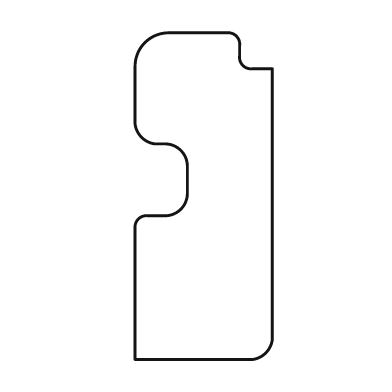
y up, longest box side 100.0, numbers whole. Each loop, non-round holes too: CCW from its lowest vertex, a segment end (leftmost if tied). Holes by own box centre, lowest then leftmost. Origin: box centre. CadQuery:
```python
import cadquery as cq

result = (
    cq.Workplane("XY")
    .moveTo(-21.0, -50.0)
    .lineTo(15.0, -50.0)
    .threePointArc((19.0, -48.0), (21.0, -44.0))
    .lineTo(21.0, 39.0)
    .lineTo(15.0, 39.0)
    .threePointArc((12.0, 40.0), (11.0, 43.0))
    .lineTo(11.0, 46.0)
    .threePointArc((10.0, 49.0), (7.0, 50.0))
    .lineTo(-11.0, 50.0)
    .threePointArc((-18.0, 47.0), (-21.0, 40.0))
    .lineTo(-21.0, 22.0)
    .threePointArc((-19.0, 18.0), (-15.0, 16.0))
    .lineTo(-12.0, 16.0)
    .threePointArc((-7.0, 14.0), (-5.0, 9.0))
    .lineTo(-5.0, 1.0)
    .threePointArc((-7.0, -4.0), (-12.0, -6.0))
    .lineTo(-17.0, -6.0)
    .threePointArc((-20.0, -7.0), (-21.0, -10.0))
    .close()
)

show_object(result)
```